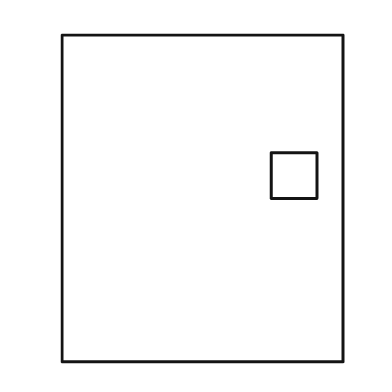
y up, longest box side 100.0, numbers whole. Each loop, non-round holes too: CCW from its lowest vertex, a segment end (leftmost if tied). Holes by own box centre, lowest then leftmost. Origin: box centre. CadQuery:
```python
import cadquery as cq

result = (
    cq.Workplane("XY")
    .moveTo(-43.0, -50.0)
    .lineTo(43.0, -50.0)
    .lineTo(43.0, 50.0)
    .lineTo(-43.0, 50.0)
    .close()
    .moveTo(21.0, 0.0)
    .lineTo(35.0, 0.0)
    .lineTo(35.0, 14.0)
    .lineTo(21.0, 14.0)
    .close()
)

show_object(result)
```